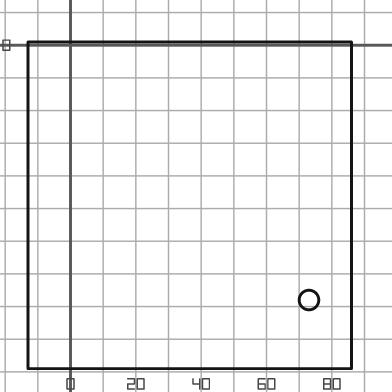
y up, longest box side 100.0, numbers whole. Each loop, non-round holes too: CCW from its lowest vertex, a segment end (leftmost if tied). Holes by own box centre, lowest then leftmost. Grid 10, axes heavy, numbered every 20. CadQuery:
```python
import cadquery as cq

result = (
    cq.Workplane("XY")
    .moveTo(-13.0, -99.0)
    .lineTo(86.0, -99.0)
    .lineTo(86.0, 1.0)
    .lineTo(-13.0, 1.0)
    .close()
    .moveTo(73.0, -78.0)
    .circle(3.0)
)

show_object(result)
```